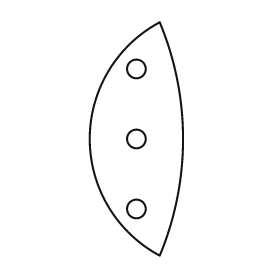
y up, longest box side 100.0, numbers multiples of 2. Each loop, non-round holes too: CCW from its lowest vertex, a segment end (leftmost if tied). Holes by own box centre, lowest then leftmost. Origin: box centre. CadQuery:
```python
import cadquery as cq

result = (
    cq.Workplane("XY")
    .moveTo(10.0, -50.0)
    .threePointArc((20.0, 0.0), (10.0, 50.0))
    .threePointArc((-20.0, 0.0), (10.0, -50.0))
    .close()
    .moveTo(0.0, -30.0)
    .circle(4.0)
    .moveTo(0.0, 0.0)
    .circle(4.0)
    .moveTo(0.0, 30.0)
    .circle(4.0)
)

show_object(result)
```